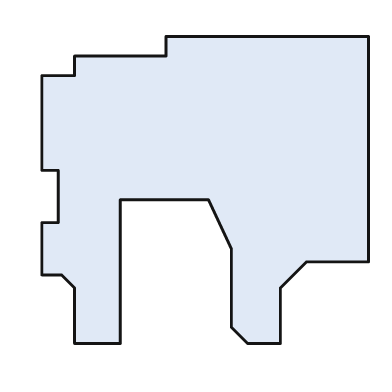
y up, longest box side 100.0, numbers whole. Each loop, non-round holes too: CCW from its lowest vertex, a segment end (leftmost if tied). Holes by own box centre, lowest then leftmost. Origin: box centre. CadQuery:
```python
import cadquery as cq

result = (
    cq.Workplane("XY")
    .moveTo(-40.0, -47.0)
    .lineTo(-26.0, -47.0)
    .lineTo(-26.0, -3.0)
    .lineTo(1.0, -3.0)
    .lineTo(8.0, -18.0)
    .lineTo(8.0, -42.0)
    .lineTo(13.0, -47.0)
    .lineTo(23.0, -47.0)
    .lineTo(23.0, -30.0)
    .lineTo(31.0, -22.0)
    .lineTo(50.0, -22.0)
    .lineTo(50.0, 47.0)
    .lineTo(-12.0, 47.0)
    .lineTo(-12.0, 41.0)
    .lineTo(-40.0, 41.0)
    .lineTo(-40.0, 35.0)
    .lineTo(-50.0, 35.0)
    .lineTo(-50.0, 6.0)
    .lineTo(-45.0, 6.0)
    .lineTo(-45.0, -10.0)
    .lineTo(-50.0, -10.0)
    .lineTo(-50.0, -26.0)
    .lineTo(-44.0, -26.0)
    .lineTo(-40.0, -30.0)
    .close()
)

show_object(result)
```